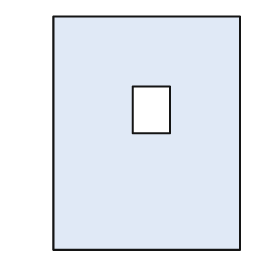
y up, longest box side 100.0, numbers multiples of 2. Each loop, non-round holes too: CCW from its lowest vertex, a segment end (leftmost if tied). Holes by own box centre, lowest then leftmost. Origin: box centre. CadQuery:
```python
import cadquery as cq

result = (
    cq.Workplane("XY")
    .moveTo(-40.0, -50.0)
    .lineTo(40.0, -50.0)
    .lineTo(40.0, 50.0)
    .lineTo(-40.0, 50.0)
    .close()
    .moveTo(-6.0, 0.0)
    .lineTo(10.0, 0.0)
    .lineTo(10.0, 20.0)
    .lineTo(-6.0, 20.0)
    .close()
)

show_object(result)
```